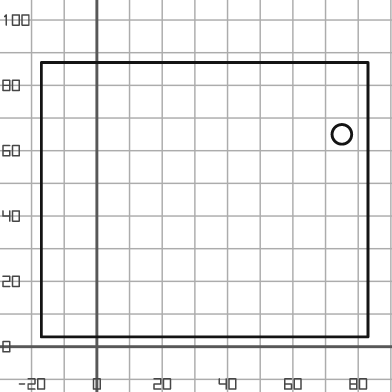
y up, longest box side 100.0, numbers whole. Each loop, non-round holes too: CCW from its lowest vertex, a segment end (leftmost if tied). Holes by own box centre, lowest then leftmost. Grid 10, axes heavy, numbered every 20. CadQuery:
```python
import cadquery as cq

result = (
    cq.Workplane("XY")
    .moveTo(-17.0, 3.0)
    .lineTo(83.0, 3.0)
    .lineTo(83.0, 87.0)
    .lineTo(-17.0, 87.0)
    .close()
    .moveTo(75.0, 65.0)
    .circle(3.0)
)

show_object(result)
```